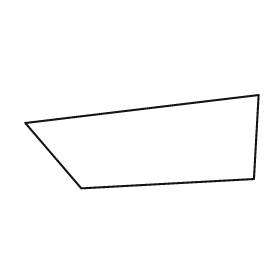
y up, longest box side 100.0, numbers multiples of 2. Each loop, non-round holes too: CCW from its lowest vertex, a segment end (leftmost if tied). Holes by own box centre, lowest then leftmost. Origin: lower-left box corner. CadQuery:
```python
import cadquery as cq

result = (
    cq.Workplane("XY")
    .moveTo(24.0, 0.0)
    .lineTo(98.0, 4.0)
    .lineTo(100.0, 40.0)
    .lineTo(0.0, 28.0)
    .close()
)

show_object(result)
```